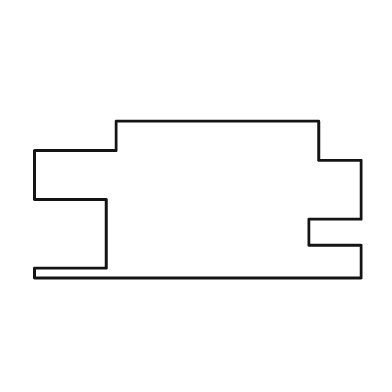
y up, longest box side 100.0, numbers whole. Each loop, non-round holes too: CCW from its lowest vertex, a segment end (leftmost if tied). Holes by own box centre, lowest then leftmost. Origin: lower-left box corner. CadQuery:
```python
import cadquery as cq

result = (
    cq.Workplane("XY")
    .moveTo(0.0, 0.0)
    .lineTo(100.0, 0.0)
    .lineTo(100.0, 10.0)
    .lineTo(84.0, 10.0)
    .lineTo(84.0, 18.0)
    .lineTo(100.0, 18.0)
    .lineTo(100.0, 36.0)
    .lineTo(87.0, 36.0)
    .lineTo(87.0, 48.0)
    .lineTo(25.0, 48.0)
    .lineTo(25.0, 39.0)
    .lineTo(0.0, 39.0)
    .lineTo(0.0, 24.0)
    .lineTo(22.0, 24.0)
    .lineTo(22.0, 3.0)
    .lineTo(0.0, 3.0)
    .close()
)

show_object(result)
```